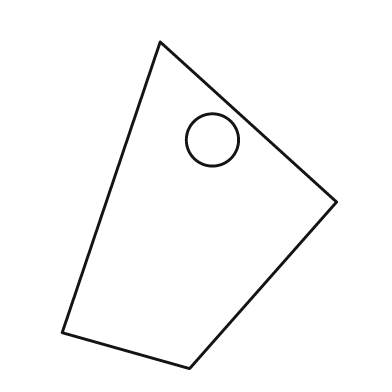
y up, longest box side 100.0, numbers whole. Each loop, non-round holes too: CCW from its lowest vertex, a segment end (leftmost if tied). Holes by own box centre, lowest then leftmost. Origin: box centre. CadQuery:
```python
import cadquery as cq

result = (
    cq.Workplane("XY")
    .moveTo(-3.0, -50.0)
    .lineTo(42.0, 1.0)
    .lineTo(-12.0, 50.0)
    .lineTo(-42.0, -39.0)
    .close()
    .moveTo(4.0, 20.0)
    .circle(8.0)
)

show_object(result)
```